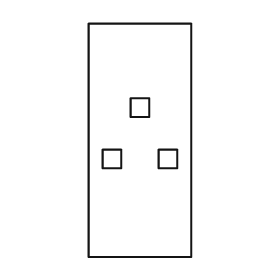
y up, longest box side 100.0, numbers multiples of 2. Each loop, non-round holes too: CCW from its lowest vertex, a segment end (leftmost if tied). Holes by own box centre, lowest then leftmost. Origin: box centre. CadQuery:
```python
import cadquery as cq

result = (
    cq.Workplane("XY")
    .moveTo(-22.0, -50.0)
    .lineTo(22.0, -50.0)
    .lineTo(22.0, 50.0)
    .lineTo(-22.0, 50.0)
    .close()
    .moveTo(-16.0, -12.0)
    .lineTo(-8.0, -12.0)
    .lineTo(-8.0, -4.0)
    .lineTo(-16.0, -4.0)
    .close()
    .moveTo(8.0, -12.0)
    .lineTo(16.0, -12.0)
    .lineTo(16.0, -4.0)
    .lineTo(8.0, -4.0)
    .close()
    .moveTo(-4.0, 10.0)
    .lineTo(4.0, 10.0)
    .lineTo(4.0, 18.0)
    .lineTo(-4.0, 18.0)
    .close()
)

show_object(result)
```